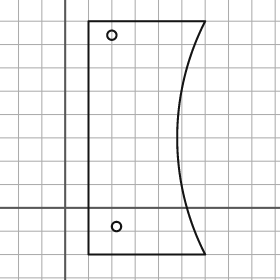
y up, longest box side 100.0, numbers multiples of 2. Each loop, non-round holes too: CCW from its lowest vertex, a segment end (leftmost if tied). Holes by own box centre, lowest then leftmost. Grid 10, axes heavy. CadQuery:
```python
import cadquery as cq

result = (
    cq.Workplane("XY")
    .moveTo(10.0, -20.0)
    .lineTo(60.0, -20.0)
    .threePointArc((48.0, 30.0), (60.0, 80.0))
    .lineTo(10.0, 80.0)
    .close()
    .moveTo(22.0, -8.0)
    .circle(2.0)
    .moveTo(20.0, 74.0)
    .circle(2.0)
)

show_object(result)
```